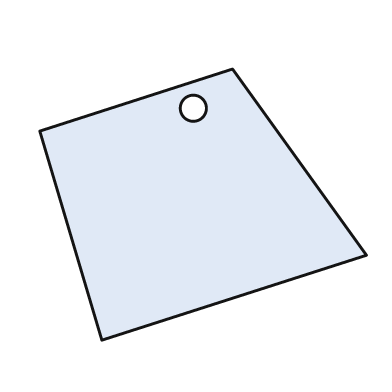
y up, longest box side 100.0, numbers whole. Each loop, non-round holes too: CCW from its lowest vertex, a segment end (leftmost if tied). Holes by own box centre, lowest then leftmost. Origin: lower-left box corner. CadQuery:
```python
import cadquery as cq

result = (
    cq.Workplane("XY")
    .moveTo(19.0, 0.0)
    .lineTo(100.0, 26.0)
    .lineTo(59.0, 83.0)
    .lineTo(0.0, 64.0)
    .close()
    .moveTo(47.0, 71.0)
    .circle(4.0)
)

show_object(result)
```